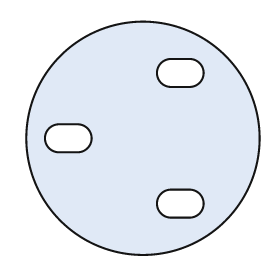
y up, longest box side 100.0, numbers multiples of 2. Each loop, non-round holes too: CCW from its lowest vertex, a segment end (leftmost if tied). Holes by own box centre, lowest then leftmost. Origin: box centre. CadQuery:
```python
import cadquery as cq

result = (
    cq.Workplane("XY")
    .moveTo(0.0, 0.0)
    .circle(50.0)
    .moveTo(12.0, -34.0)
    .lineTo(20.0, -34.0)
    .threePointArc((26.0, -28.0), (20.0, -22.0))
    .lineTo(12.0, -22.0)
    .threePointArc((6.0, -28.0), (12.0, -34.0))
    .close()
    .moveTo(-36.0, -6.0)
    .lineTo(-28.0, -6.0)
    .threePointArc((-22.0, 0.0), (-28.0, 6.0))
    .lineTo(-36.0, 6.0)
    .threePointArc((-42.0, 0.0), (-36.0, -6.0))
    .close()
    .moveTo(12.0, 22.0)
    .lineTo(20.0, 22.0)
    .threePointArc((26.0, 28.0), (20.0, 34.0))
    .lineTo(12.0, 34.0)
    .threePointArc((6.0, 28.0), (12.0, 22.0))
    .close()
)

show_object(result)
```